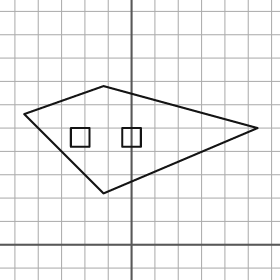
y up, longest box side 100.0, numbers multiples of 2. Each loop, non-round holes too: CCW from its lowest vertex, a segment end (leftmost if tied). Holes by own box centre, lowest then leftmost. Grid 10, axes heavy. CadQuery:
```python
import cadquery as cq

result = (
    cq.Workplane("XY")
    .moveTo(-12.0, 22.0)
    .lineTo(54.0, 50.0)
    .lineTo(-12.0, 68.0)
    .lineTo(-46.0, 56.0)
    .close()
    .moveTo(-26.0, 42.0)
    .lineTo(-18.0, 42.0)
    .lineTo(-18.0, 50.0)
    .lineTo(-26.0, 50.0)
    .close()
    .moveTo(-4.0, 42.0)
    .lineTo(4.0, 42.0)
    .lineTo(4.0, 50.0)
    .lineTo(-4.0, 50.0)
    .close()
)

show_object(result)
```